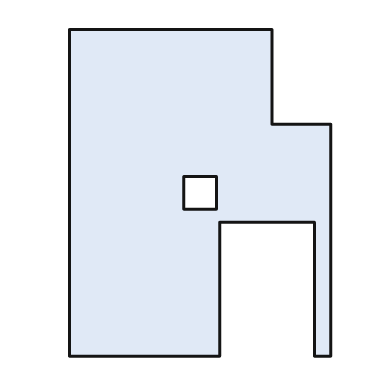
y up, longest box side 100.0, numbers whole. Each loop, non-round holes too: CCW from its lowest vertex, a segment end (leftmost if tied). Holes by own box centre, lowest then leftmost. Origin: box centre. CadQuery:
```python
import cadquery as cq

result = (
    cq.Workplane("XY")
    .moveTo(-40.0, -50.0)
    .lineTo(6.0, -50.0)
    .lineTo(6.0, -9.0)
    .lineTo(35.0, -9.0)
    .lineTo(35.0, -50.0)
    .lineTo(40.0, -50.0)
    .lineTo(40.0, 21.0)
    .lineTo(22.0, 21.0)
    .lineTo(22.0, 50.0)
    .lineTo(-40.0, 50.0)
    .close()
    .moveTo(-5.0, -5.0)
    .lineTo(5.0, -5.0)
    .lineTo(5.0, 5.0)
    .lineTo(-5.0, 5.0)
    .close()
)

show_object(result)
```